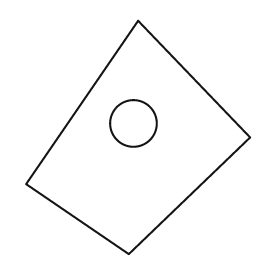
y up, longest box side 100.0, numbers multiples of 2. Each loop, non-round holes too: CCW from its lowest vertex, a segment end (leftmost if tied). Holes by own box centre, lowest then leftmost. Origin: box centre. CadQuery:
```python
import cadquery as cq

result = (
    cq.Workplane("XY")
    .moveTo(-4.0, -50.0)
    .lineTo(48.0, 0.0)
    .lineTo(0.0, 50.0)
    .lineTo(-48.0, -20.0)
    .close()
    .moveTo(-2.0, 6.0)
    .circle(10.0)
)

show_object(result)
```